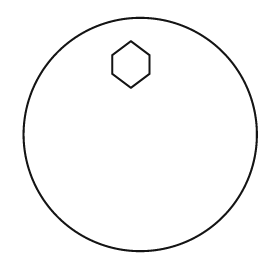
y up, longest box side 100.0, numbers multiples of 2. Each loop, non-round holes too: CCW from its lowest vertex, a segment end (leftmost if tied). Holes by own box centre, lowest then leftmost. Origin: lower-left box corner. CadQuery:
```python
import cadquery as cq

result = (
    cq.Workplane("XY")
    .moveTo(50.0, 50.0)
    .circle(50.0)
    .moveTo(46.0, 70.0)
    .lineTo(54.0, 76.0)
    .lineTo(54.0, 84.0)
    .lineTo(46.0, 90.0)
    .lineTo(38.0, 84.0)
    .lineTo(38.0, 76.0)
    .close()
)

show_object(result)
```